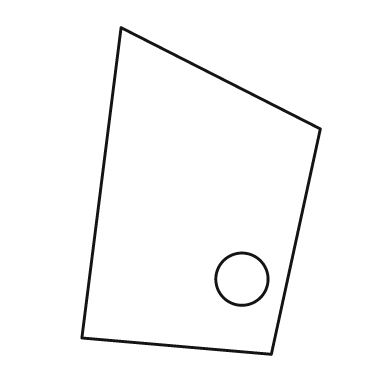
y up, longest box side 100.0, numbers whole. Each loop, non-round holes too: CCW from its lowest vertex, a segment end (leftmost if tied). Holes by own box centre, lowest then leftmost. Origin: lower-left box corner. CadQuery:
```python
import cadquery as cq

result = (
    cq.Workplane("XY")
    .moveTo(58.0, 0.0)
    .lineTo(73.0, 69.0)
    .lineTo(12.0, 100.0)
    .lineTo(0.0, 5.0)
    .close()
    .moveTo(49.0, 23.0)
    .circle(8.0)
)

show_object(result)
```